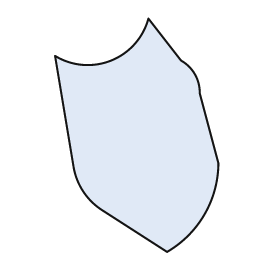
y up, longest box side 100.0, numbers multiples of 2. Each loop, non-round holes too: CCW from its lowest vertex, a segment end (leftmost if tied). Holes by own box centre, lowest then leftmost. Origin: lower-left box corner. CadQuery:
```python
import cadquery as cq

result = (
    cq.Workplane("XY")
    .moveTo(48.0, 0.0)
    .threePointArc((64.0, 16.0), (70.0, 38.0))
    .lineTo(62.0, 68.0)
    .threePointArc((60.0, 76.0), (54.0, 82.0))
    .lineTo(40.0, 100.0)
    .threePointArc((24.0, 82.0), (0.0, 84.0))
    .lineTo(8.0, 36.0)
    .threePointArc((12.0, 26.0), (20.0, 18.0))
    .close()
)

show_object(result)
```